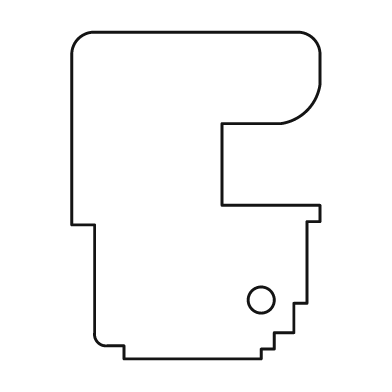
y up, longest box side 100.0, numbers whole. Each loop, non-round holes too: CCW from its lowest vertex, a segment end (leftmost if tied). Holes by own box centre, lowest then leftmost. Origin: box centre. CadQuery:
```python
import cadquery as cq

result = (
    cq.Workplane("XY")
    .moveTo(-22.0, -50.0)
    .lineTo(20.0, -50.0)
    .lineTo(20.0, -47.0)
    .lineTo(24.0, -47.0)
    .lineTo(24.0, -42.0)
    .lineTo(30.0, -42.0)
    .lineTo(30.0, -33.0)
    .lineTo(34.0, -33.0)
    .lineTo(34.0, -8.0)
    .lineTo(38.0, -8.0)
    .lineTo(38.0, -3.0)
    .lineTo(8.0, -3.0)
    .lineTo(8.0, 22.0)
    .lineTo(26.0, 22.0)
    .threePointArc((34.0, 26.0), (38.0, 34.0))
    .lineTo(38.0, 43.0)
    .threePointArc((36.0, 48.0), (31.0, 50.0))
    .lineTo(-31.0, 50.0)
    .threePointArc((-36.0, 48.0), (-38.0, 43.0))
    .lineTo(-38.0, -9.0)
    .lineTo(-31.0, -9.0)
    .lineTo(-31.0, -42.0)
    .threePointArc((-30.0, -45.0), (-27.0, -46.0))
    .lineTo(-22.0, -46.0)
    .close()
    .moveTo(20.0, -32.0)
    .circle(4.0)
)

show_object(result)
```